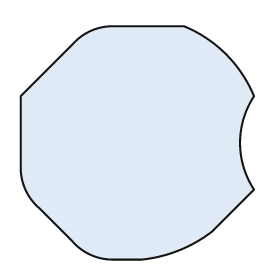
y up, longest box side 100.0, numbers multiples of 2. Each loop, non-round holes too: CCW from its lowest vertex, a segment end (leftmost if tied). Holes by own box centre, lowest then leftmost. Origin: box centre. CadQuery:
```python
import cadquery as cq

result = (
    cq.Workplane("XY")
    .moveTo(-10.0, -50.0)
    .lineTo(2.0, -50.0)
    .threePointArc((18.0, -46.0), (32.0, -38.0))
    .lineTo(50.0, -20.0)
    .threePointArc((44.0, 0.0), (50.0, 20.0))
    .threePointArc((38.0, 38.0), (20.0, 50.0))
    .lineTo(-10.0, 50.0)
    .threePointArc((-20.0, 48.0), (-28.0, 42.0))
    .lineTo(-50.0, 20.0)
    .lineTo(-50.0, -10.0)
    .threePointArc((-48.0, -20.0), (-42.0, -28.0))
    .lineTo(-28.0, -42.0)
    .threePointArc((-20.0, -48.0), (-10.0, -50.0))
    .close()
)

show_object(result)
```